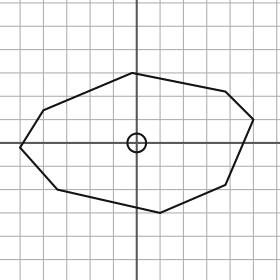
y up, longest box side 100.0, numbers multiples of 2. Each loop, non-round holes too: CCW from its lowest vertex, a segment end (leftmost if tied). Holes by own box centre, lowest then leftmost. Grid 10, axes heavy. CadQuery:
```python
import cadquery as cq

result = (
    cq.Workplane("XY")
    .moveTo(10.0, -30.0)
    .lineTo(38.0, -18.0)
    .lineTo(50.0, 10.0)
    .lineTo(38.0, 22.0)
    .lineTo(-2.0, 30.0)
    .lineTo(-40.0, 14.0)
    .lineTo(-50.0, -2.0)
    .lineTo(-34.0, -20.0)
    .close()
    .moveTo(0.0, 0.0)
    .circle(4.0)
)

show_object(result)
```